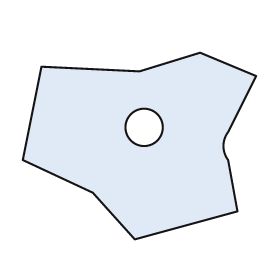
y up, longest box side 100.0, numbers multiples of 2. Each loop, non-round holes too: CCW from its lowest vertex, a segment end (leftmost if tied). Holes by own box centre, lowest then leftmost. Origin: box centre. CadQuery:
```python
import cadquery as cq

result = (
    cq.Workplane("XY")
    .moveTo(-2.0, -40.0)
    .lineTo(42.0, -28.0)
    .lineTo(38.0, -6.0)
    .threePointArc((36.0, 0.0), (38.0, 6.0))
    .lineTo(50.0, 30.0)
    .lineTo(26.0, 40.0)
    .lineTo(0.0, 32.0)
    .lineTo(-42.0, 34.0)
    .lineTo(-50.0, -6.0)
    .lineTo(-20.0, -20.0)
    .close()
    .moveTo(2.0, 8.0)
    .circle(8.0)
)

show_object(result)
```